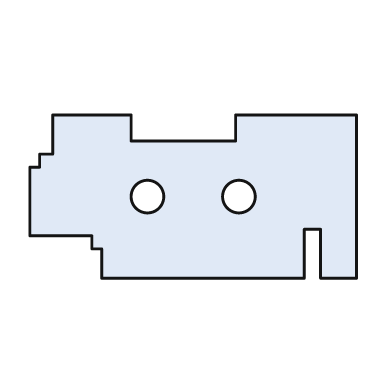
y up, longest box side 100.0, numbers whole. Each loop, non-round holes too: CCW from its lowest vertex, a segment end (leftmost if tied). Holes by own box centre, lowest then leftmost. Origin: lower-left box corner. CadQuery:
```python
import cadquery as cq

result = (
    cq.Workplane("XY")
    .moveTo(22.0, 0.0)
    .lineTo(84.0, 0.0)
    .lineTo(84.0, 15.0)
    .lineTo(89.0, 15.0)
    .lineTo(89.0, 0.0)
    .lineTo(100.0, 0.0)
    .lineTo(100.0, 50.0)
    .lineTo(63.0, 50.0)
    .lineTo(63.0, 42.0)
    .lineTo(31.0, 42.0)
    .lineTo(31.0, 50.0)
    .lineTo(7.0, 50.0)
    .lineTo(7.0, 38.0)
    .lineTo(3.0, 38.0)
    .lineTo(3.0, 34.0)
    .lineTo(0.0, 34.0)
    .lineTo(0.0, 13.0)
    .lineTo(19.0, 13.0)
    .lineTo(19.0, 9.0)
    .lineTo(22.0, 9.0)
    .close()
    .moveTo(36.0, 25.0)
    .circle(5.0)
    .moveTo(64.0, 25.0)
    .circle(5.0)
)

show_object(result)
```